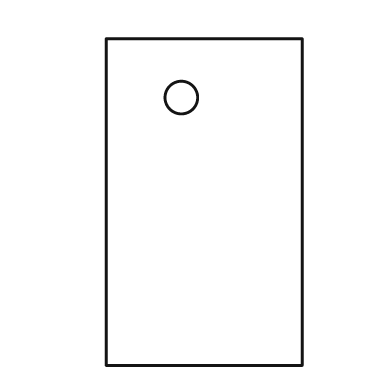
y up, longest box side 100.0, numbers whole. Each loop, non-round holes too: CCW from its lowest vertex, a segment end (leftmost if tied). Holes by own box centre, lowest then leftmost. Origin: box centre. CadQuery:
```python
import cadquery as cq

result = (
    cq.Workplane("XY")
    .moveTo(-30.0, -50.0)
    .lineTo(30.0, -50.0)
    .lineTo(30.0, 50.0)
    .lineTo(-30.0, 50.0)
    .close()
    .moveTo(-7.0, 32.0)
    .circle(5.0)
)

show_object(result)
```